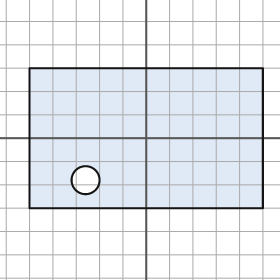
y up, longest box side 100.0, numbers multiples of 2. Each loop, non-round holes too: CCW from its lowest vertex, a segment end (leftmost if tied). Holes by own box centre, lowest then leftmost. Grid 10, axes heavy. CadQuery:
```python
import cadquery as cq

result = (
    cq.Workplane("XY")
    .moveTo(-50.0, -30.0)
    .lineTo(50.0, -30.0)
    .lineTo(50.0, 30.0)
    .lineTo(-50.0, 30.0)
    .close()
    .moveTo(-26.0, -18.0)
    .circle(6.0)
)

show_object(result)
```